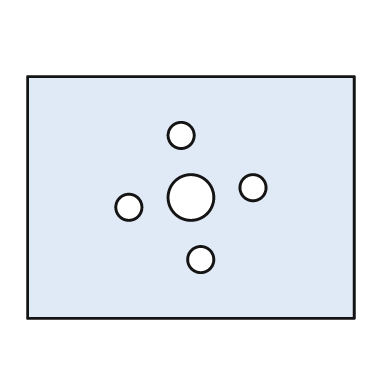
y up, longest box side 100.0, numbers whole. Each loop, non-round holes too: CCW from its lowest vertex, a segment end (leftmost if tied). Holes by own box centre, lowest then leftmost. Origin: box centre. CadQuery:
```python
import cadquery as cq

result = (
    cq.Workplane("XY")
    .moveTo(-50.0, -37.0)
    .lineTo(50.0, -37.0)
    .lineTo(50.0, 37.0)
    .lineTo(-50.0, 37.0)
    .close()
    .moveTo(3.0, -19.0)
    .circle(4.0)
    .moveTo(-19.0, -3.0)
    .circle(4.0)
    .moveTo(0.0, 0.0)
    .circle(7.0)
    .moveTo(19.0, 3.0)
    .circle(4.0)
    .moveTo(-3.0, 19.0)
    .circle(4.0)
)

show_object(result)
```